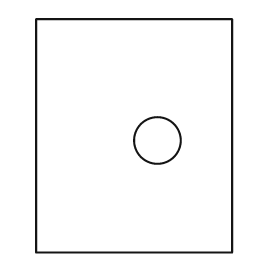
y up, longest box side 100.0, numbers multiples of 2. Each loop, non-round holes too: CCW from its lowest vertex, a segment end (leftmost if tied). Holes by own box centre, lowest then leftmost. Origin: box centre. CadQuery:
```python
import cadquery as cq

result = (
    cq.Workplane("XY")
    .moveTo(-42.0, -50.0)
    .lineTo(42.0, -50.0)
    .lineTo(42.0, 50.0)
    .lineTo(-42.0, 50.0)
    .close()
    .moveTo(10.0, -2.0)
    .circle(10.0)
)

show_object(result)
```